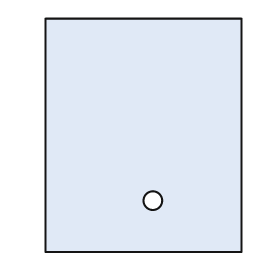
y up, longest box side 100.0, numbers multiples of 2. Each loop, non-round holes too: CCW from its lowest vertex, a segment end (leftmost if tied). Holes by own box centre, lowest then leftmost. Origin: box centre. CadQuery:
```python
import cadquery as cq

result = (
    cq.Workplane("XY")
    .moveTo(-42.0, -50.0)
    .lineTo(42.0, -50.0)
    .lineTo(42.0, 50.0)
    .lineTo(-42.0, 50.0)
    .close()
    .moveTo(4.0, -28.0)
    .circle(4.0)
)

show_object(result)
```